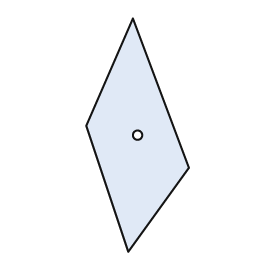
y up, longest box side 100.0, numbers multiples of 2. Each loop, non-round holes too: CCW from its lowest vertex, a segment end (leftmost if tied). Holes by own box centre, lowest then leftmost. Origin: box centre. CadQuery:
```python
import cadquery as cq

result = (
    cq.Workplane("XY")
    .moveTo(-4.0, -50.0)
    .lineTo(22.0, -14.0)
    .lineTo(-2.0, 50.0)
    .lineTo(-22.0, 4.0)
    .close()
    .moveTo(0.0, 0.0)
    .circle(2.0)
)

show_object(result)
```